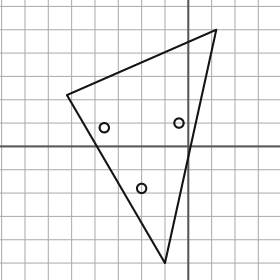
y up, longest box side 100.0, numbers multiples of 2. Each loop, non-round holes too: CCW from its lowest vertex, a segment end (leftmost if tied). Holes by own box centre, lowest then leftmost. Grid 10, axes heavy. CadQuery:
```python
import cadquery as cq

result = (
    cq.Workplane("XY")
    .moveTo(-10.0, -50.0)
    .lineTo(12.0, 50.0)
    .lineTo(-52.0, 22.0)
    .close()
    .moveTo(-20.0, -18.0)
    .circle(2.0)
    .moveTo(-36.0, 8.0)
    .circle(2.0)
    .moveTo(-4.0, 10.0)
    .circle(2.0)
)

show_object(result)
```